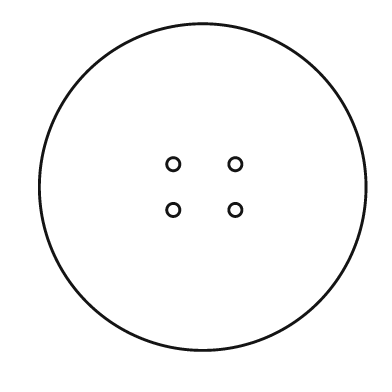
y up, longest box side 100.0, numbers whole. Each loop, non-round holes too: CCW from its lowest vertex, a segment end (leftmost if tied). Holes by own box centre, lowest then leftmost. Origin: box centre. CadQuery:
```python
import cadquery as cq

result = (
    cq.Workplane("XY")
    .moveTo(0.0, 0.0)
    .circle(50.0)
    .moveTo(-9.0, -7.0)
    .circle(2.0)
    .moveTo(10.0, -7.0)
    .circle(2.0)
    .moveTo(-9.0, 7.0)
    .circle(2.0)
    .moveTo(10.0, 7.0)
    .circle(2.0)
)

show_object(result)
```